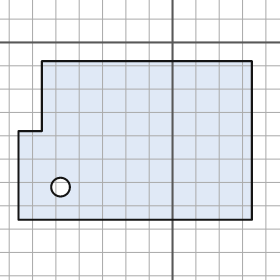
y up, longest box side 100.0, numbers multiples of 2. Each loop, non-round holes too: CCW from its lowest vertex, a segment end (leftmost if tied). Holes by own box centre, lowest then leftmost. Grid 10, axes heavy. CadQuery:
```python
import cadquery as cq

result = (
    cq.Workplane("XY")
    .moveTo(-66.0, -76.0)
    .lineTo(34.0, -76.0)
    .lineTo(34.0, -8.0)
    .lineTo(-56.0, -8.0)
    .lineTo(-56.0, -38.0)
    .lineTo(-66.0, -38.0)
    .close()
    .moveTo(-48.0, -62.0)
    .circle(4.0)
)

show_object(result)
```